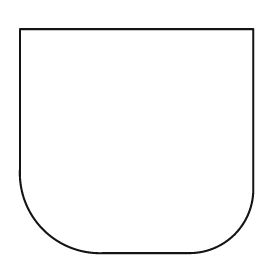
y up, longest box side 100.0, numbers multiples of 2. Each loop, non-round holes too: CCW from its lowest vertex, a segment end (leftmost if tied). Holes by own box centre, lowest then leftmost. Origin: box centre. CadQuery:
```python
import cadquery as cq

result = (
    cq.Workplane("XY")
    .moveTo(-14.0, -48.0)
    .lineTo(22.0, -48.0)
    .threePointArc((42.0, -40.0), (50.0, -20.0))
    .lineTo(50.0, 48.0)
    .lineTo(-50.0, 48.0)
    .lineTo(-50.0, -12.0)
    .threePointArc((-40.0, -38.0), (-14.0, -48.0))
    .close()
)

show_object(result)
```